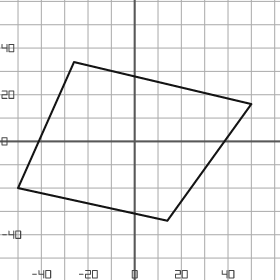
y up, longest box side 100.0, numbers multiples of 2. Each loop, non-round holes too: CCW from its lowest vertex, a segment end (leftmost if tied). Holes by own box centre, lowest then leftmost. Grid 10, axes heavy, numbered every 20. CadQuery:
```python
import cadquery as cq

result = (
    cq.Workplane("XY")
    .moveTo(14.0, -34.0)
    .lineTo(50.0, 16.0)
    .lineTo(-26.0, 34.0)
    .lineTo(-50.0, -20.0)
    .close()
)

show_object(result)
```